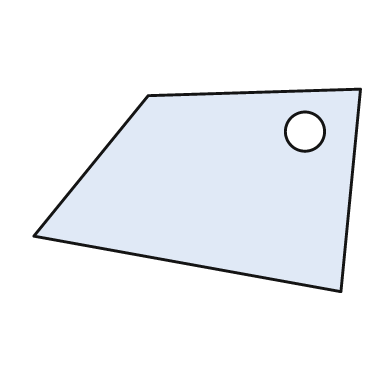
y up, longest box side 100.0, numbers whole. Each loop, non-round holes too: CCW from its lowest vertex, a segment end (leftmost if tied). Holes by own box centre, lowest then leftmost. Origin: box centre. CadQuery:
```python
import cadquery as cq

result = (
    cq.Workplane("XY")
    .moveTo(44.0, -31.0)
    .lineTo(50.0, 31.0)
    .lineTo(-15.0, 29.0)
    .lineTo(-50.0, -14.0)
    .close()
    .moveTo(33.0, 18.0)
    .circle(6.0)
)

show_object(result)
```